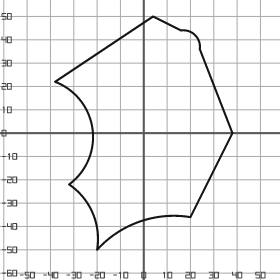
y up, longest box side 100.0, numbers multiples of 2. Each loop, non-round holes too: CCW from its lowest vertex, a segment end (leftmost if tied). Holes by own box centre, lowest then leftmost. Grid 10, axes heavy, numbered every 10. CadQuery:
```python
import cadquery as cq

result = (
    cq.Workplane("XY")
    .moveTo(-20.0, -50.0)
    .threePointArc((-2.0, -38.0), (20.0, -36.0))
    .lineTo(38.0, 0.0)
    .lineTo(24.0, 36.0)
    .threePointArc((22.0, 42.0), (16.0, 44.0))
    .lineTo(4.0, 50.0)
    .lineTo(-38.0, 22.0)
    .threePointArc((-22.0, 2.0), (-32.0, -22.0))
    .threePointArc((-22.0, -34.0), (-20.0, -50.0))
    .close()
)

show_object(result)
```